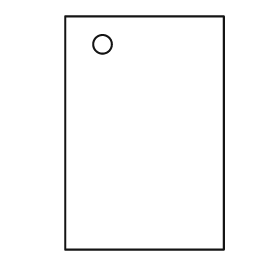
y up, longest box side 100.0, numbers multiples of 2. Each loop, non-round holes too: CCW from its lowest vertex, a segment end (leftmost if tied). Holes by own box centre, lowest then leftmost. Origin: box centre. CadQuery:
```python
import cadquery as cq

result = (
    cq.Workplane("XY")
    .moveTo(-34.0, -50.0)
    .lineTo(34.0, -50.0)
    .lineTo(34.0, 50.0)
    .lineTo(-34.0, 50.0)
    .close()
    .moveTo(-18.0, 38.0)
    .circle(4.0)
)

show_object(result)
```